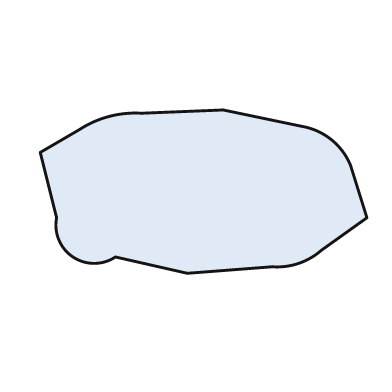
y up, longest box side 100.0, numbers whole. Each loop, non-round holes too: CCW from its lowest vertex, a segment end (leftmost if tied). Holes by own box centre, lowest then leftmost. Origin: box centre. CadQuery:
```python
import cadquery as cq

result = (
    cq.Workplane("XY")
    .moveTo(-5.0, -25.0)
    .lineTo(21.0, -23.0)
    .threePointArc((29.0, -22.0), (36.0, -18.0))
    .lineTo(50.0, -8.0)
    .lineTo(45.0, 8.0)
    .threePointArc((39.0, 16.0), (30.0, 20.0))
    .lineTo(6.0, 25.0)
    .lineTo(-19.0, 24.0)
    .threePointArc((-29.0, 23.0), (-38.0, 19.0))
    .lineTo(-50.0, 12.0)
    .lineTo(-45.0, -8.0)
    .threePointArc((-40.0, -20.0), (-27.0, -20.0))
    .close()
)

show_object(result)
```